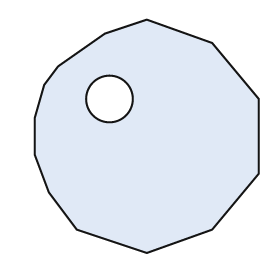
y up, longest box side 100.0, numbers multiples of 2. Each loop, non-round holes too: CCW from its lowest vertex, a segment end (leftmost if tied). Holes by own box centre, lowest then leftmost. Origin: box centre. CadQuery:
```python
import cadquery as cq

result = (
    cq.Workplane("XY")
    .moveTo(0.0, -50.0)
    .lineTo(28.0, -40.0)
    .lineTo(48.0, -16.0)
    .lineTo(48.0, 16.0)
    .lineTo(28.0, 40.0)
    .lineTo(0.0, 50.0)
    .lineTo(-18.0, 44.0)
    .lineTo(-38.0, 30.0)
    .lineTo(-44.0, 22.0)
    .lineTo(-48.0, 8.0)
    .lineTo(-48.0, -8.0)
    .lineTo(-42.0, -24.0)
    .lineTo(-30.0, -40.0)
    .close()
    .moveTo(-16.0, 16.0)
    .circle(10.0)
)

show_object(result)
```